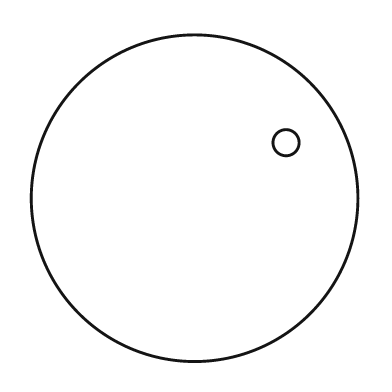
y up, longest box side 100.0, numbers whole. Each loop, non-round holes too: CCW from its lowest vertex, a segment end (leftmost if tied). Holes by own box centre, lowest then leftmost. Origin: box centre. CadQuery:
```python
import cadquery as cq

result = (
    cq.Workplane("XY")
    .moveTo(0.0, 0.0)
    .circle(50.0)
    .moveTo(28.0, 17.0)
    .circle(4.0)
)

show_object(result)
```